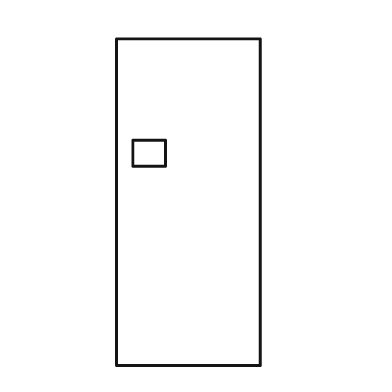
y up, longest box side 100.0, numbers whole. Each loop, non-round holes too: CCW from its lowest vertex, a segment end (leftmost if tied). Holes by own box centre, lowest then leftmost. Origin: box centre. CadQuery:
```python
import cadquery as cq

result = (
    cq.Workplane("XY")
    .moveTo(-22.0, -50.0)
    .lineTo(22.0, -50.0)
    .lineTo(22.0, 50.0)
    .lineTo(-22.0, 50.0)
    .close()
    .moveTo(-17.0, 11.0)
    .lineTo(-7.0, 11.0)
    .lineTo(-7.0, 19.0)
    .lineTo(-17.0, 19.0)
    .close()
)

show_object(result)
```